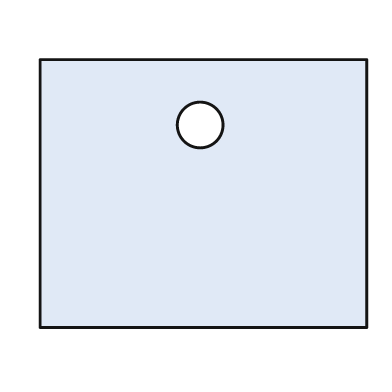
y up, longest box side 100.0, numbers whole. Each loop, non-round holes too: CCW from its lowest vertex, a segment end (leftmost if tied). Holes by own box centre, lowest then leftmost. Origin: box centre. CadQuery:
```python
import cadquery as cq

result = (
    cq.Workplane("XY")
    .moveTo(-50.0, -41.0)
    .lineTo(50.0, -41.0)
    .lineTo(50.0, 41.0)
    .lineTo(-50.0, 41.0)
    .close()
    .moveTo(-1.0, 21.0)
    .circle(7.0)
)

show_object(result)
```